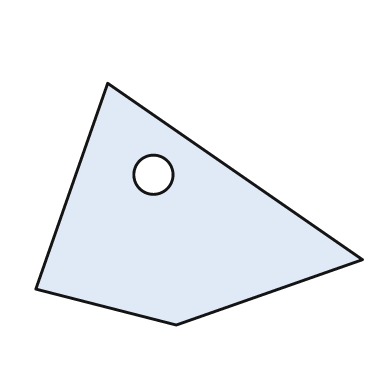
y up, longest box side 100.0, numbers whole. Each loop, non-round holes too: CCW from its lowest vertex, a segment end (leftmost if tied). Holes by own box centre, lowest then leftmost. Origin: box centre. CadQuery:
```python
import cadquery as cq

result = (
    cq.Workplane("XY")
    .moveTo(-7.0, -37.0)
    .lineTo(50.0, -17.0)
    .lineTo(-28.0, 37.0)
    .lineTo(-50.0, -26.0)
    .close()
    .moveTo(-14.0, 9.0)
    .circle(6.0)
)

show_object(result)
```